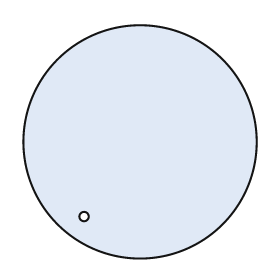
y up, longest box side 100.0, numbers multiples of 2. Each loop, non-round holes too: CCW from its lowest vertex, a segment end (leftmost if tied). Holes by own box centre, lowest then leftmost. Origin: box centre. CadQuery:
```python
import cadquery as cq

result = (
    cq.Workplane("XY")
    .moveTo(0.0, 0.0)
    .circle(50.0)
    .moveTo(-24.0, -32.0)
    .circle(2.0)
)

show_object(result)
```